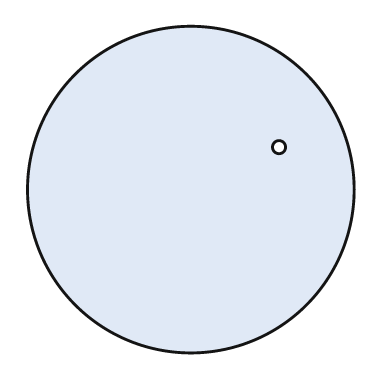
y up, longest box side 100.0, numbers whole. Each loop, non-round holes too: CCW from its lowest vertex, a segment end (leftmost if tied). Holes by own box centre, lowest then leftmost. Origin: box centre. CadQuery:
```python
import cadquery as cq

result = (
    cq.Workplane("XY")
    .moveTo(0.0, 0.0)
    .circle(50.0)
    .moveTo(27.0, 13.0)
    .circle(2.0)
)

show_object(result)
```